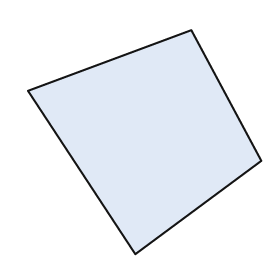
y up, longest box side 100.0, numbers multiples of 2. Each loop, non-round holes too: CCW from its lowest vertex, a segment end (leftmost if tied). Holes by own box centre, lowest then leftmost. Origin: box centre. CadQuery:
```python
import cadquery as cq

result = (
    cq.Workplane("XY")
    .moveTo(-4.0, -48.0)
    .lineTo(50.0, -8.0)
    .lineTo(20.0, 48.0)
    .lineTo(-50.0, 22.0)
    .close()
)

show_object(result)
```